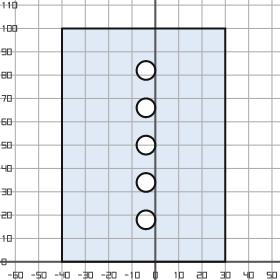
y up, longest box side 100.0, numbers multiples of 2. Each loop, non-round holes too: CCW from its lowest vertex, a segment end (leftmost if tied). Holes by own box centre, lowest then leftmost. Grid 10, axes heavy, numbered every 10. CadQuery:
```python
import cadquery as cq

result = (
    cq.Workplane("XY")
    .moveTo(-40.0, 0.0)
    .lineTo(30.0, 0.0)
    .lineTo(30.0, 100.0)
    .lineTo(-40.0, 100.0)
    .close()
    .moveTo(-4.0, 18.0)
    .circle(4.0)
    .moveTo(-4.0, 34.0)
    .circle(4.0)
    .moveTo(-4.0, 50.0)
    .circle(4.0)
    .moveTo(-4.0, 66.0)
    .circle(4.0)
    .moveTo(-4.0, 82.0)
    .circle(4.0)
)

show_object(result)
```